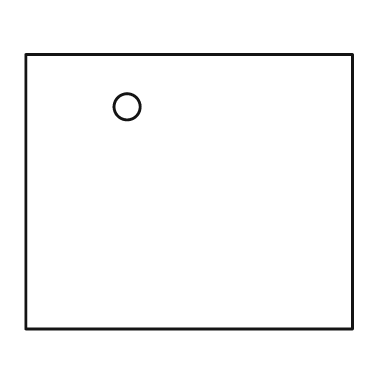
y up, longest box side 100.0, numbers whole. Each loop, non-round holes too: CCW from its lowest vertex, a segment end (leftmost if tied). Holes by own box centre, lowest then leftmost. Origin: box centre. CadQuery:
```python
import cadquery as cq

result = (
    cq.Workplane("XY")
    .moveTo(-50.0, -42.0)
    .lineTo(50.0, -42.0)
    .lineTo(50.0, 42.0)
    .lineTo(-50.0, 42.0)
    .close()
    .moveTo(-19.0, 26.0)
    .circle(4.0)
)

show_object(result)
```